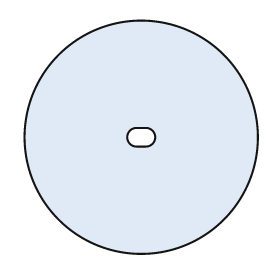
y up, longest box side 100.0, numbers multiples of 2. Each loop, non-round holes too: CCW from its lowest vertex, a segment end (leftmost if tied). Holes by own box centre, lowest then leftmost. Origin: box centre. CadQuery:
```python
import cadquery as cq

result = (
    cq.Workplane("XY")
    .moveTo(0.0, 0.0)
    .circle(50.0)
    .moveTo(-2.0, -4.0)
    .lineTo(2.0, -4.0)
    .threePointArc((6.0, 0.0), (2.0, 4.0))
    .lineTo(-2.0, 4.0)
    .threePointArc((-6.0, 0.0), (-2.0, -4.0))
    .close()
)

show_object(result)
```